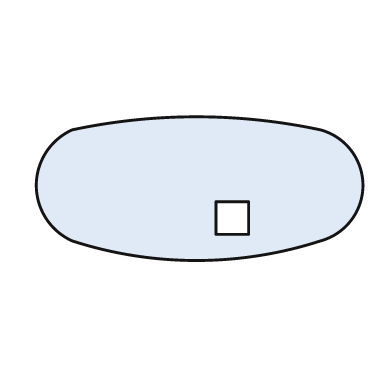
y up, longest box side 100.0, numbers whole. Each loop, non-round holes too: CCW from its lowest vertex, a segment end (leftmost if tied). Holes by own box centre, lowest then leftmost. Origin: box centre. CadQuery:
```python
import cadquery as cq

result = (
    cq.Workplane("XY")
    .moveTo(-39.0, -16.0)
    .threePointArc((-1.0, -22.0), (37.0, -16.0))
    .threePointArc((50.0, 1.0), (37.0, 18.0))
    .threePointArc((-1.0, 22.0), (-39.0, 18.0))
    .threePointArc((-50.0, 1.0), (-39.0, -16.0))
    .close()
    .moveTo(5.0, -14.0)
    .lineTo(15.0, -14.0)
    .lineTo(15.0, -4.0)
    .lineTo(5.0, -4.0)
    .close()
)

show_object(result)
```